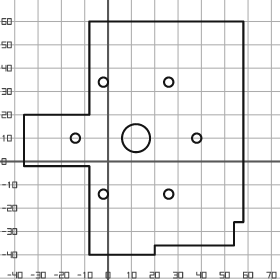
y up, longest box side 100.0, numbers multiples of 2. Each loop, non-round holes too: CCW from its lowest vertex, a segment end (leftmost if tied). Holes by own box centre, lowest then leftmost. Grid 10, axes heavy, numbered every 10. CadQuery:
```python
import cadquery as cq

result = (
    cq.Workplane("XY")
    .moveTo(-8.0, -40.0)
    .lineTo(20.0, -40.0)
    .lineTo(20.0, -36.0)
    .lineTo(54.0, -36.0)
    .lineTo(54.0, -26.0)
    .lineTo(58.0, -26.0)
    .lineTo(58.0, 60.0)
    .lineTo(-8.0, 60.0)
    .lineTo(-8.0, 20.0)
    .lineTo(-36.0, 20.0)
    .lineTo(-36.0, -2.0)
    .lineTo(-8.0, -2.0)
    .close()
    .moveTo(-2.0, -14.0)
    .circle(2.0)
    .moveTo(26.0, -14.0)
    .circle(2.0)
    .moveTo(-14.0, 10.0)
    .circle(2.0)
    .moveTo(12.0, 10.0)
    .circle(6.0)
    .moveTo(38.0, 10.0)
    .circle(2.0)
    .moveTo(-2.0, 34.0)
    .circle(2.0)
    .moveTo(26.0, 34.0)
    .circle(2.0)
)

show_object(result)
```